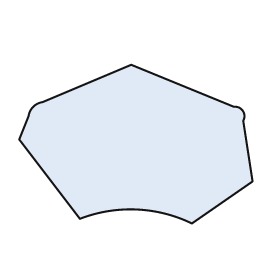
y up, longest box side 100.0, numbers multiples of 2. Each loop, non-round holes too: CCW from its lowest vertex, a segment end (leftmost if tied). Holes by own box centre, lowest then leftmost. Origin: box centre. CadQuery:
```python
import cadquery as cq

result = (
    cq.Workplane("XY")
    .moveTo(24.0, -34.0)
    .lineTo(50.0, -16.0)
    .lineTo(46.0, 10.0)
    .threePointArc((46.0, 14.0), (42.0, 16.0))
    .lineTo(-2.0, 34.0)
    .lineTo(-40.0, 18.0)
    .threePointArc((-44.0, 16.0), (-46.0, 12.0))
    .lineTo(-50.0, 2.0)
    .lineTo(-24.0, -32.0)
    .threePointArc((0.0, -28.0), (24.0, -34.0))
    .close()
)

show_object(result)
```